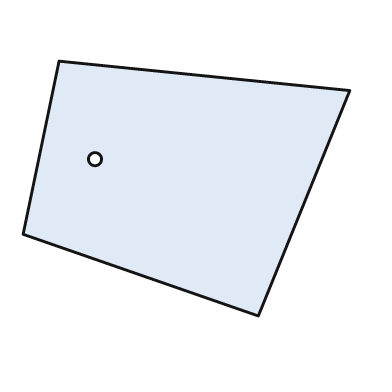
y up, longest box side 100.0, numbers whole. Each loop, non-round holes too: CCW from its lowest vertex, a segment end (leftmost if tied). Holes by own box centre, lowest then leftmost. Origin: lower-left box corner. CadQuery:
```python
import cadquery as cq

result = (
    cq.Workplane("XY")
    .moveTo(72.0, 0.0)
    .lineTo(100.0, 69.0)
    .lineTo(11.0, 78.0)
    .lineTo(0.0, 25.0)
    .close()
    .moveTo(22.0, 48.0)
    .circle(2.0)
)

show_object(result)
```